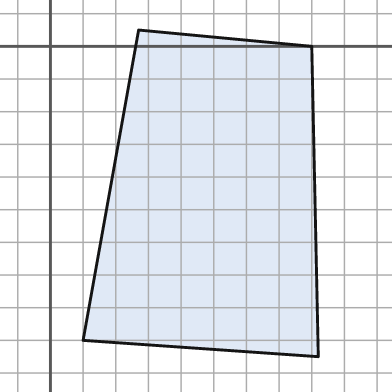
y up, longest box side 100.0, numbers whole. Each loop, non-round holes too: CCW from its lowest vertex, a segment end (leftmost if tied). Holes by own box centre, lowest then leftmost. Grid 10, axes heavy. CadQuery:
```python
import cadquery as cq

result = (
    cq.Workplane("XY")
    .moveTo(82.0, -95.0)
    .lineTo(80.0, 0.0)
    .lineTo(27.0, 5.0)
    .lineTo(10.0, -90.0)
    .close()
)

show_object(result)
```